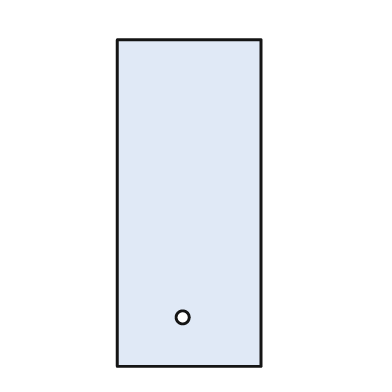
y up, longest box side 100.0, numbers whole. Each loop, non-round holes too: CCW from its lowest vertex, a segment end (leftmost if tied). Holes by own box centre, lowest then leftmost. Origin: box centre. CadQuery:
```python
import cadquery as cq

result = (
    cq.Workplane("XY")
    .moveTo(-22.0, -50.0)
    .lineTo(22.0, -50.0)
    .lineTo(22.0, 50.0)
    .lineTo(-22.0, 50.0)
    .close()
    .moveTo(-2.0, -35.0)
    .circle(2.0)
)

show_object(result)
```